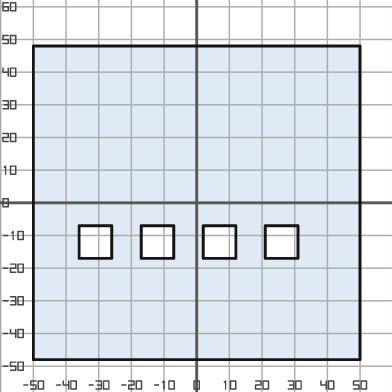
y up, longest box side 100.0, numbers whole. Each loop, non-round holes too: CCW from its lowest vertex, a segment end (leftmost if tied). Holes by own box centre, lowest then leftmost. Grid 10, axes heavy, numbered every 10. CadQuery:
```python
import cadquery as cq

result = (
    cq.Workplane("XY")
    .moveTo(-50.0, -48.0)
    .lineTo(50.0, -48.0)
    .lineTo(50.0, 48.0)
    .lineTo(-50.0, 48.0)
    .close()
    .moveTo(-36.0, -17.0)
    .lineTo(-26.0, -17.0)
    .lineTo(-26.0, -7.0)
    .lineTo(-36.0, -7.0)
    .close()
    .moveTo(-17.0, -17.0)
    .lineTo(-7.0, -17.0)
    .lineTo(-7.0, -7.0)
    .lineTo(-17.0, -7.0)
    .close()
    .moveTo(2.0, -17.0)
    .lineTo(12.0, -17.0)
    .lineTo(12.0, -7.0)
    .lineTo(2.0, -7.0)
    .close()
    .moveTo(21.0, -17.0)
    .lineTo(31.0, -17.0)
    .lineTo(31.0, -7.0)
    .lineTo(21.0, -7.0)
    .close()
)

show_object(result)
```